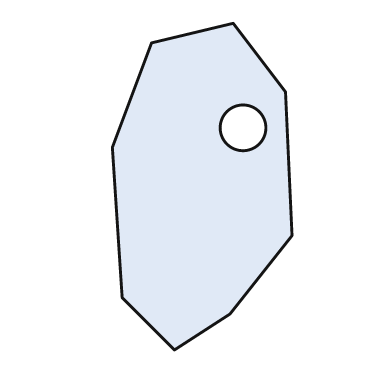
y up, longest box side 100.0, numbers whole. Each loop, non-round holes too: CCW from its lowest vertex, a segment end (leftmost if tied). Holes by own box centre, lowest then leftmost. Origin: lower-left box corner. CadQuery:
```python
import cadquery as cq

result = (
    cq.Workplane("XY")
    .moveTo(19.0, 0.0)
    .lineTo(36.0, 11.0)
    .lineTo(55.0, 35.0)
    .lineTo(53.0, 79.0)
    .lineTo(37.0, 100.0)
    .lineTo(12.0, 94.0)
    .lineTo(0.0, 62.0)
    .lineTo(3.0, 16.0)
    .close()
    .moveTo(40.0, 68.0)
    .circle(7.0)
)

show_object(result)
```